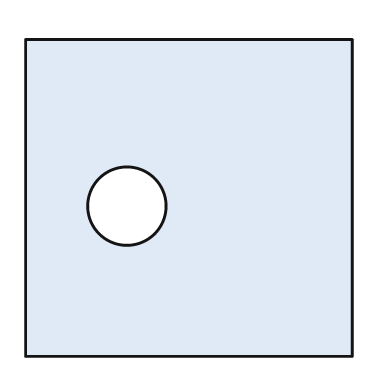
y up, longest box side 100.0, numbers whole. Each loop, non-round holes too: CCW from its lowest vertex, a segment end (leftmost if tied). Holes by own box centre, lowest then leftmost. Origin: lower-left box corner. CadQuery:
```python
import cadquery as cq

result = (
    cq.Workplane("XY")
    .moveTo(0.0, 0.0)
    .lineTo(100.0, 0.0)
    .lineTo(100.0, 97.0)
    .lineTo(0.0, 97.0)
    .close()
    .moveTo(31.0, 46.0)
    .circle(12.0)
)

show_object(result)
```